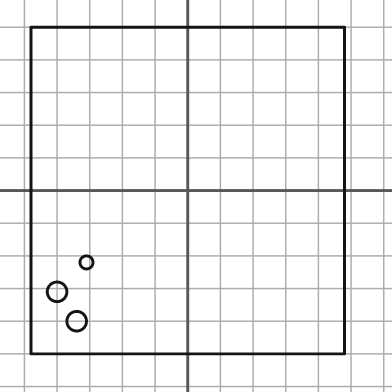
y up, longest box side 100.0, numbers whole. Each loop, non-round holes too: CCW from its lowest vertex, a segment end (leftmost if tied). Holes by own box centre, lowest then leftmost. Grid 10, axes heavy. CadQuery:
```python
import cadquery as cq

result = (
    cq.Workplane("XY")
    .moveTo(-48.0, -50.0)
    .lineTo(48.0, -50.0)
    .lineTo(48.0, 50.0)
    .lineTo(-48.0, 50.0)
    .close()
    .moveTo(-34.0, -40.0)
    .circle(3.0)
    .moveTo(-40.0, -31.0)
    .circle(3.0)
    .moveTo(-31.0, -22.0)
    .circle(2.0)
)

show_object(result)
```